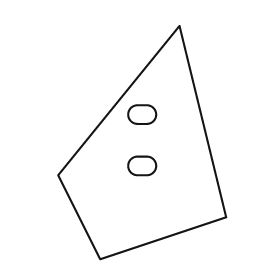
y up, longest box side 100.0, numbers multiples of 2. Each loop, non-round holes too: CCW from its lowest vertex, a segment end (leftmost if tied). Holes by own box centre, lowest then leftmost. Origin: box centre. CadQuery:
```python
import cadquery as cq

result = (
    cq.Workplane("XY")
    .moveTo(-18.0, -50.0)
    .lineTo(36.0, -32.0)
    .lineTo(16.0, 50.0)
    .lineTo(-36.0, -14.0)
    .close()
    .moveTo(-2.0, -14.0)
    .lineTo(2.0, -14.0)
    .threePointArc((6.0, -10.0), (2.0, -6.0))
    .lineTo(-2.0, -6.0)
    .threePointArc((-6.0, -10.0), (-2.0, -14.0))
    .close()
    .moveTo(-2.0, 8.0)
    .lineTo(2.0, 8.0)
    .threePointArc((6.0, 12.0), (2.0, 16.0))
    .lineTo(-2.0, 16.0)
    .threePointArc((-6.0, 12.0), (-2.0, 8.0))
    .close()
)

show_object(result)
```